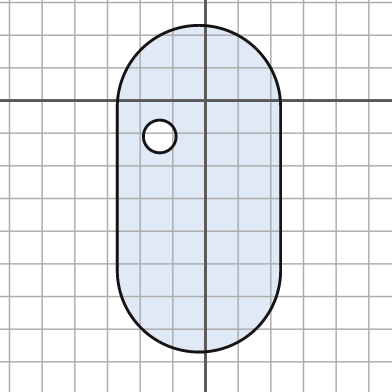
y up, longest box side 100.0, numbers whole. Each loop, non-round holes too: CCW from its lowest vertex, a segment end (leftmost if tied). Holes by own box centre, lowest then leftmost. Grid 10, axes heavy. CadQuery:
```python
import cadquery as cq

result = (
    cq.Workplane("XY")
    .moveTo(-27.0, -52.0)
    .threePointArc((-2.0, -77.0), (23.0, -52.0))
    .lineTo(23.0, -2.0)
    .threePointArc((-2.0, 23.0), (-27.0, -2.0))
    .close()
    .moveTo(-14.0, -11.0)
    .circle(5.0)
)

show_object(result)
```